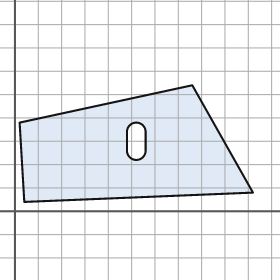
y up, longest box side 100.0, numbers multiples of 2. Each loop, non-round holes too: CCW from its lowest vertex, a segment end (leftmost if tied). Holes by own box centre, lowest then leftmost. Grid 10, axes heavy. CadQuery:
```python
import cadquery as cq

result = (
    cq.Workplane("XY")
    .moveTo(4.0, 4.0)
    .lineTo(102.0, 8.0)
    .lineTo(76.0, 54.0)
    .lineTo(2.0, 38.0)
    .close()
    .moveTo(48.0, 26.0)
    .threePointArc((52.0, 22.0), (56.0, 26.0))
    .lineTo(56.0, 34.0)
    .threePointArc((52.0, 38.0), (48.0, 34.0))
    .close()
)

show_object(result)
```